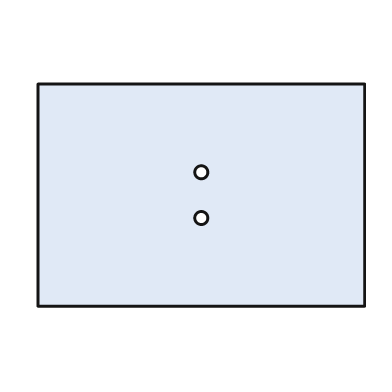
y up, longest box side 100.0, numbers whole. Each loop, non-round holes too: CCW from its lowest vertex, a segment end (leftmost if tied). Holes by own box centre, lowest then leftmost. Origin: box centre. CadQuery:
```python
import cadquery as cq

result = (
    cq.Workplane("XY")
    .moveTo(-50.0, -34.0)
    .lineTo(50.0, -34.0)
    .lineTo(50.0, 34.0)
    .lineTo(-50.0, 34.0)
    .close()
    .moveTo(0.0, -7.0)
    .circle(2.0)
    .moveTo(0.0, 7.0)
    .circle(2.0)
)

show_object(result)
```